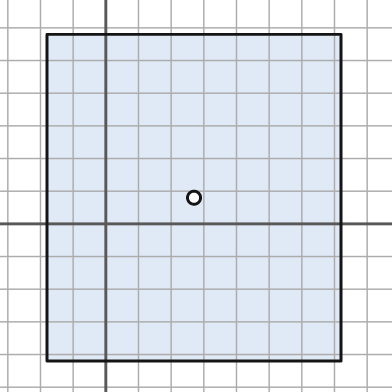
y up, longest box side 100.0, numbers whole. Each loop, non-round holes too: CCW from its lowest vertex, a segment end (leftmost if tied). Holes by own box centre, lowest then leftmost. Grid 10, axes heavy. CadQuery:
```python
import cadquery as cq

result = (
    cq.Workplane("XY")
    .moveTo(-18.0, -42.0)
    .lineTo(72.0, -42.0)
    .lineTo(72.0, 58.0)
    .lineTo(-18.0, 58.0)
    .close()
    .moveTo(27.0, 8.0)
    .circle(2.0)
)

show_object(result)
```